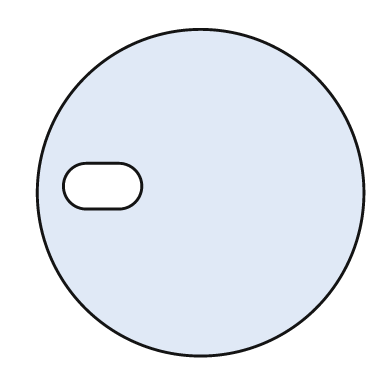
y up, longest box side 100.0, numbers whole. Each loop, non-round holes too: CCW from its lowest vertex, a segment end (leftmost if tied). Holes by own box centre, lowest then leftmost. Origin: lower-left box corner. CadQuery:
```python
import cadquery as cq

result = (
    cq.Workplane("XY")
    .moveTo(50.0, 50.0)
    .circle(50.0)
    .moveTo(15.0, 45.0)
    .lineTo(25.0, 45.0)
    .threePointArc((32.0, 52.0), (25.0, 59.0))
    .lineTo(15.0, 59.0)
    .threePointArc((8.0, 52.0), (15.0, 45.0))
    .close()
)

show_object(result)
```